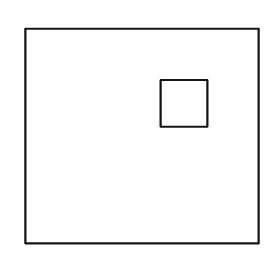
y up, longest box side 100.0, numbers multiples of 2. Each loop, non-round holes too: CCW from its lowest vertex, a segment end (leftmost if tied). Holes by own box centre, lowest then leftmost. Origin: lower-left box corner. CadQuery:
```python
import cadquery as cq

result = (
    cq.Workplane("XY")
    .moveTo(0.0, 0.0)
    .lineTo(100.0, 0.0)
    .lineTo(100.0, 92.0)
    .lineTo(0.0, 92.0)
    .close()
    .moveTo(58.0, 50.0)
    .lineTo(78.0, 50.0)
    .lineTo(78.0, 70.0)
    .lineTo(58.0, 70.0)
    .close()
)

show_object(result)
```